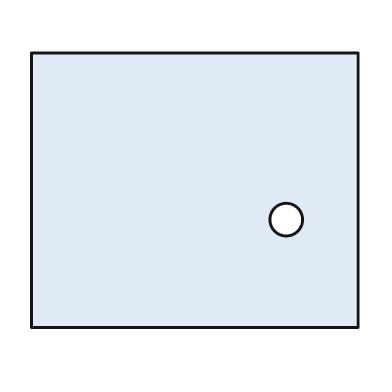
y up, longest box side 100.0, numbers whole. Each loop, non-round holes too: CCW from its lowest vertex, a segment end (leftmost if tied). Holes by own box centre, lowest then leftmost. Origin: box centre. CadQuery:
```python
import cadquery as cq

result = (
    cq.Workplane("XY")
    .moveTo(-50.0, -42.0)
    .lineTo(50.0, -42.0)
    .lineTo(50.0, 42.0)
    .lineTo(-50.0, 42.0)
    .close()
    .moveTo(28.0, -9.0)
    .circle(5.0)
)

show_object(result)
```